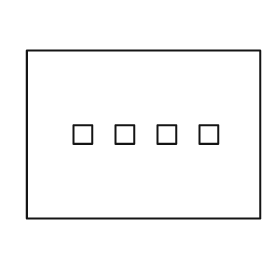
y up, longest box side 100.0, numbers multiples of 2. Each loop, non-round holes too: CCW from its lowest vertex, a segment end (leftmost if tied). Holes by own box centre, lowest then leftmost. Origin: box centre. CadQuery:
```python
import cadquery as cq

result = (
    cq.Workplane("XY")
    .moveTo(-50.0, -36.0)
    .lineTo(50.0, -36.0)
    .lineTo(50.0, 36.0)
    .lineTo(-50.0, 36.0)
    .close()
    .moveTo(-30.0, -4.0)
    .lineTo(-22.0, -4.0)
    .lineTo(-22.0, 4.0)
    .lineTo(-30.0, 4.0)
    .close()
    .moveTo(-12.0, -4.0)
    .lineTo(-4.0, -4.0)
    .lineTo(-4.0, 4.0)
    .lineTo(-12.0, 4.0)
    .close()
    .moveTo(6.0, -4.0)
    .lineTo(14.0, -4.0)
    .lineTo(14.0, 4.0)
    .lineTo(6.0, 4.0)
    .close()
    .moveTo(24.0, -4.0)
    .lineTo(32.0, -4.0)
    .lineTo(32.0, 4.0)
    .lineTo(24.0, 4.0)
    .close()
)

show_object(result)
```